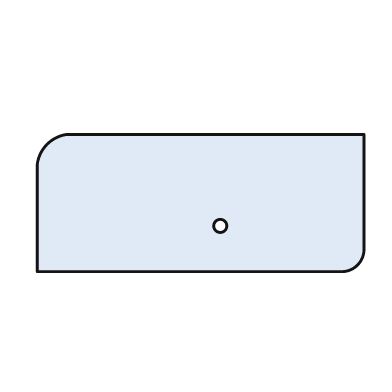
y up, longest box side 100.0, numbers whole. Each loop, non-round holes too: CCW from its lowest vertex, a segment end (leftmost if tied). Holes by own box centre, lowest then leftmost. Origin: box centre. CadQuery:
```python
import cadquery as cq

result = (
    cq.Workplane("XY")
    .moveTo(-50.0, -21.0)
    .lineTo(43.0, -21.0)
    .threePointArc((48.0, -19.0), (50.0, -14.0))
    .lineTo(50.0, 21.0)
    .lineTo(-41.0, 21.0)
    .threePointArc((-47.0, 18.0), (-50.0, 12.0))
    .close()
    .moveTo(6.0, -7.0)
    .circle(2.0)
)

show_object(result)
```